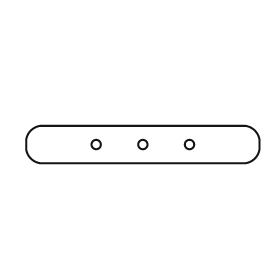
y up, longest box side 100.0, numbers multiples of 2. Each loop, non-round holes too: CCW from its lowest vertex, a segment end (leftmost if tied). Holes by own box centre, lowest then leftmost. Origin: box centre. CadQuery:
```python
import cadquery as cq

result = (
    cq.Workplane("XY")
    .moveTo(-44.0, -8.0)
    .lineTo(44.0, -8.0)
    .threePointArc((48.0, -6.0), (50.0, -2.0))
    .lineTo(50.0, 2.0)
    .threePointArc((48.0, 6.0), (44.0, 8.0))
    .lineTo(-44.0, 8.0)
    .threePointArc((-48.0, 6.0), (-50.0, 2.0))
    .lineTo(-50.0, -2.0)
    .threePointArc((-48.0, -6.0), (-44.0, -8.0))
    .close()
    .moveTo(-20.0, 0.0)
    .circle(2.0)
    .moveTo(0.0, 0.0)
    .circle(2.0)
    .moveTo(20.0, 0.0)
    .circle(2.0)
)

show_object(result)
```